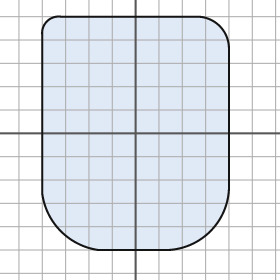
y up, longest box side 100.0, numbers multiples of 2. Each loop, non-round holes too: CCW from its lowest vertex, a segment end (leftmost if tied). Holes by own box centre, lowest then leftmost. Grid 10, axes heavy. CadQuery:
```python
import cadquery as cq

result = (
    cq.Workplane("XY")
    .moveTo(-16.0, -50.0)
    .lineTo(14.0, -50.0)
    .threePointArc((32.0, -42.0), (40.0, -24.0))
    .lineTo(40.0, 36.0)
    .threePointArc((36.0, 46.0), (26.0, 50.0))
    .lineTo(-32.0, 50.0)
    .threePointArc((-38.0, 48.0), (-40.0, 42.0))
    .lineTo(-40.0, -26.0)
    .threePointArc((-32.0, -42.0), (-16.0, -50.0))
    .close()
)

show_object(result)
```